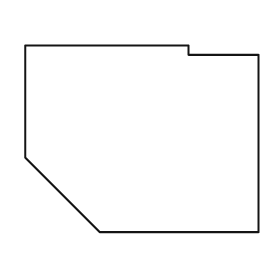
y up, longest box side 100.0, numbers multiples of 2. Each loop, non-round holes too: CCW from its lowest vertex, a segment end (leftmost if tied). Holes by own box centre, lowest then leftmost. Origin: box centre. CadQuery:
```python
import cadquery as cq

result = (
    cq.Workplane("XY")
    .moveTo(-18.0, -40.0)
    .lineTo(50.0, -40.0)
    .lineTo(50.0, 36.0)
    .lineTo(20.0, 36.0)
    .lineTo(20.0, 40.0)
    .lineTo(-50.0, 40.0)
    .lineTo(-50.0, -8.0)
    .close()
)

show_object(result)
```